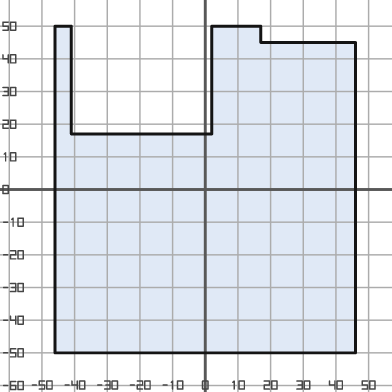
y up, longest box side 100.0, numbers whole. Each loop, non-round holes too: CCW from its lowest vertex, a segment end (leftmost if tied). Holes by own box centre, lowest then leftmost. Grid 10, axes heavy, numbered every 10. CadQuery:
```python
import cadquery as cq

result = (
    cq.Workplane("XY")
    .moveTo(-46.0, -50.0)
    .lineTo(46.0, -50.0)
    .lineTo(46.0, 45.0)
    .lineTo(17.0, 45.0)
    .lineTo(17.0, 50.0)
    .lineTo(2.0, 50.0)
    .lineTo(2.0, 17.0)
    .lineTo(-41.0, 17.0)
    .lineTo(-41.0, 50.0)
    .lineTo(-46.0, 50.0)
    .close()
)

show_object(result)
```